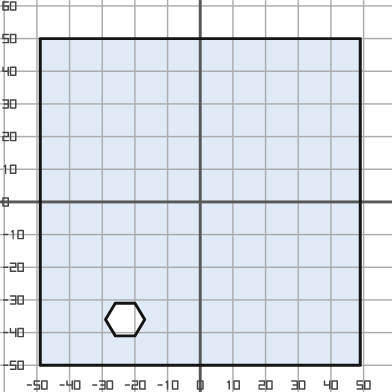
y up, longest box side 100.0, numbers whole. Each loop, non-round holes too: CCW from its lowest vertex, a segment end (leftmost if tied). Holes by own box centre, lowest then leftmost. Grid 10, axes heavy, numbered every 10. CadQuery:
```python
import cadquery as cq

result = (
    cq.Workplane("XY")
    .moveTo(-49.0, -50.0)
    .lineTo(49.0, -50.0)
    .lineTo(49.0, 50.0)
    .lineTo(-49.0, 50.0)
    .close()
    .moveTo(-26.0, -41.0)
    .lineTo(-20.0, -41.0)
    .lineTo(-17.0, -36.0)
    .lineTo(-20.0, -31.0)
    .lineTo(-26.0, -31.0)
    .lineTo(-29.0, -36.0)
    .close()
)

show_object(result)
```